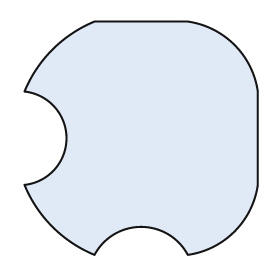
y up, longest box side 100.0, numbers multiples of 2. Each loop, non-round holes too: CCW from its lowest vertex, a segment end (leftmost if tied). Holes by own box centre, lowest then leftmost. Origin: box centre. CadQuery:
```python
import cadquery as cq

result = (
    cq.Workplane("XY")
    .moveTo(-20.0, -50.0)
    .threePointArc((0.0, -38.0), (20.0, -50.0))
    .threePointArc((40.0, -40.0), (50.0, -20.0))
    .lineTo(50.0, 20.0)
    .threePointArc((40.0, 40.0), (20.0, 50.0))
    .lineTo(-20.0, 50.0)
    .threePointArc((-38.0, 38.0), (-50.0, 20.0))
    .threePointArc((-32.0, 0.0), (-50.0, -20.0))
    .threePointArc((-38.0, -38.0), (-20.0, -50.0))
    .close()
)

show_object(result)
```